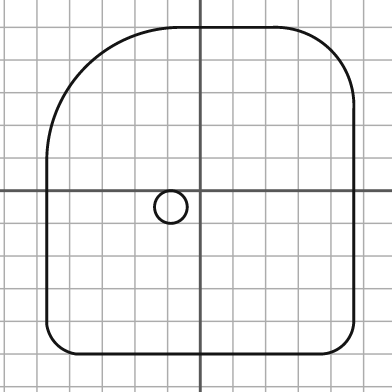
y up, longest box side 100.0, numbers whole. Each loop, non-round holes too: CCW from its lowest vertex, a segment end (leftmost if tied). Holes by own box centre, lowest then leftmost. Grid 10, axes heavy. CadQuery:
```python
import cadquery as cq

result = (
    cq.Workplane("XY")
    .moveTo(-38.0, -50.0)
    .lineTo(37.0, -50.0)
    .threePointArc((44.0, -47.0), (47.0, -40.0))
    .lineTo(47.0, 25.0)
    .threePointArc((40.0, 43.0), (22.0, 50.0))
    .lineTo(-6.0, 50.0)
    .threePointArc((-35.0, 38.0), (-47.0, 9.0))
    .lineTo(-47.0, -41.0)
    .threePointArc((-44.0, -47.0), (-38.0, -50.0))
    .close()
    .moveTo(-9.0, -5.0)
    .circle(5.0)
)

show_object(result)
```